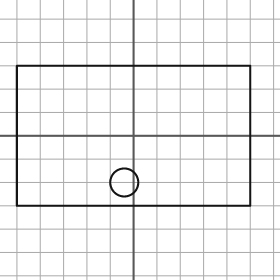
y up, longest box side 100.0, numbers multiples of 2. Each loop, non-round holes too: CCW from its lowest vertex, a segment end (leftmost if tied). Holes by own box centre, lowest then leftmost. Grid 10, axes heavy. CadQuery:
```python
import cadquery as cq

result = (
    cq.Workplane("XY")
    .moveTo(-50.0, -30.0)
    .lineTo(50.0, -30.0)
    .lineTo(50.0, 30.0)
    .lineTo(-50.0, 30.0)
    .close()
    .moveTo(-4.0, -20.0)
    .circle(6.0)
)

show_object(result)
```